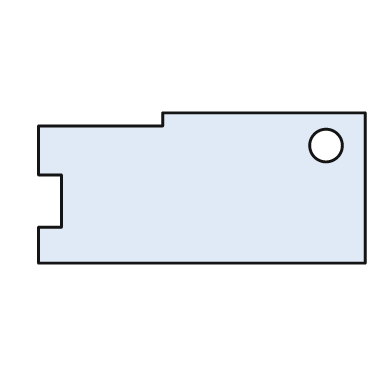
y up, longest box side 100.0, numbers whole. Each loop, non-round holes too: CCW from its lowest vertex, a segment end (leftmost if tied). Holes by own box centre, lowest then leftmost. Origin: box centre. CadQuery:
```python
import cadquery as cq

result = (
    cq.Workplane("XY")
    .moveTo(-50.0, -23.0)
    .lineTo(50.0, -23.0)
    .lineTo(50.0, 23.0)
    .lineTo(-12.0, 23.0)
    .lineTo(-12.0, 19.0)
    .lineTo(-50.0, 19.0)
    .lineTo(-50.0, 4.0)
    .lineTo(-43.0, 4.0)
    .lineTo(-43.0, -12.0)
    .lineTo(-50.0, -12.0)
    .close()
    .moveTo(38.0, 13.0)
    .circle(5.0)
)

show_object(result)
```